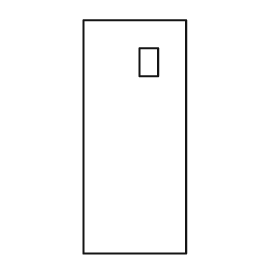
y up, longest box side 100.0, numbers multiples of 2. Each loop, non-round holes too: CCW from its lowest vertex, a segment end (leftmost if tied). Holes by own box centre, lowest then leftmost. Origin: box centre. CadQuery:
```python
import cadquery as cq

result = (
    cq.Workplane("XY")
    .moveTo(-22.0, -50.0)
    .lineTo(22.0, -50.0)
    .lineTo(22.0, 50.0)
    .lineTo(-22.0, 50.0)
    .close()
    .moveTo(2.0, 26.0)
    .lineTo(10.0, 26.0)
    .lineTo(10.0, 38.0)
    .lineTo(2.0, 38.0)
    .close()
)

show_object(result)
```